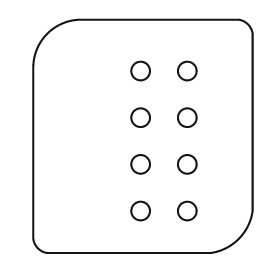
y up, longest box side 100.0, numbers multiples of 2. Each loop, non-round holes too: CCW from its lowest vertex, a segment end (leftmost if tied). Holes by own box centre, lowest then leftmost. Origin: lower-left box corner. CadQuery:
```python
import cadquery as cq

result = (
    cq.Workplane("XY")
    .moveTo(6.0, 0.0)
    .lineTo(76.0, 0.0)
    .threePointArc((88.0, 6.0), (94.0, 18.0))
    .lineTo(94.0, 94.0)
    .threePointArc((92.0, 98.0), (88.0, 100.0))
    .lineTo(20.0, 100.0)
    .threePointArc((6.0, 94.0), (0.0, 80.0))
    .lineTo(0.0, 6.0)
    .threePointArc((2.0, 2.0), (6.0, 0.0))
    .close()
    .moveTo(46.0, 18.0)
    .circle(4.0)
    .moveTo(66.0, 18.0)
    .circle(4.0)
    .moveTo(46.0, 38.0)
    .circle(4.0)
    .moveTo(66.0, 38.0)
    .circle(4.0)
    .moveTo(46.0, 58.0)
    .circle(4.0)
    .moveTo(66.0, 58.0)
    .circle(4.0)
    .moveTo(46.0, 78.0)
    .circle(4.0)
    .moveTo(66.0, 78.0)
    .circle(4.0)
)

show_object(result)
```